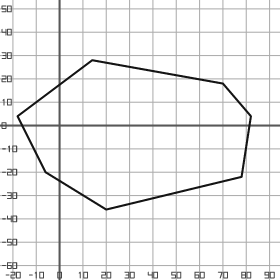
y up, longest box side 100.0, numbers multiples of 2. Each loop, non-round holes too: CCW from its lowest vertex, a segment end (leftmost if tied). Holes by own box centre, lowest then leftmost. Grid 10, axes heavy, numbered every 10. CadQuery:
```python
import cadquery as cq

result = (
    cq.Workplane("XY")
    .moveTo(20.0, -36.0)
    .lineTo(78.0, -22.0)
    .lineTo(82.0, 4.0)
    .lineTo(70.0, 18.0)
    .lineTo(14.0, 28.0)
    .lineTo(-18.0, 4.0)
    .lineTo(-6.0, -20.0)
    .close()
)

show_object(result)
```